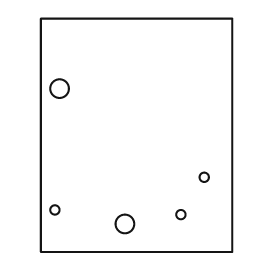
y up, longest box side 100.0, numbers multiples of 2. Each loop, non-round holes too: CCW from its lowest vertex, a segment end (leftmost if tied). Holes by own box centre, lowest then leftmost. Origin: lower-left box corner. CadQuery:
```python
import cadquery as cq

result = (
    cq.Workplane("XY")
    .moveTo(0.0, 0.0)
    .lineTo(82.0, 0.0)
    .lineTo(82.0, 100.0)
    .lineTo(0.0, 100.0)
    .close()
    .moveTo(36.0, 12.0)
    .circle(4.0)
    .moveTo(60.0, 16.0)
    .circle(2.0)
    .moveTo(6.0, 18.0)
    .circle(2.0)
    .moveTo(70.0, 32.0)
    .circle(2.0)
    .moveTo(8.0, 70.0)
    .circle(4.0)
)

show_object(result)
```